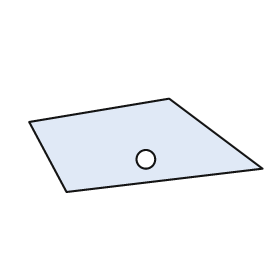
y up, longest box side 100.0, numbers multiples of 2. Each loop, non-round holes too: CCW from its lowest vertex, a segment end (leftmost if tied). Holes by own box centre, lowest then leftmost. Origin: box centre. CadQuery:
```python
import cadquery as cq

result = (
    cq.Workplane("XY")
    .moveTo(-34.0, -20.0)
    .lineTo(50.0, -10.0)
    .lineTo(10.0, 20.0)
    .lineTo(-50.0, 10.0)
    .close()
    .moveTo(0.0, -6.0)
    .circle(4.0)
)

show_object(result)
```